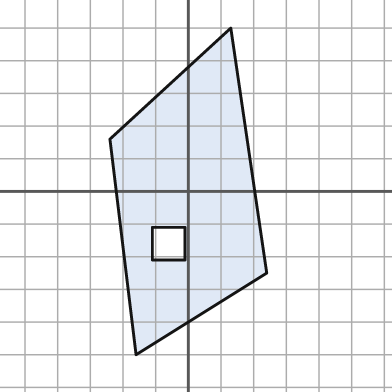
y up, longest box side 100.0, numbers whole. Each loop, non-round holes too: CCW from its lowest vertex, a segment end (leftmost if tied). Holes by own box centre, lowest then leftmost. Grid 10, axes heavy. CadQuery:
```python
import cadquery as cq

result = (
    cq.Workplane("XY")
    .moveTo(-16.0, -50.0)
    .lineTo(24.0, -25.0)
    .lineTo(13.0, 50.0)
    .lineTo(-24.0, 16.0)
    .close()
    .moveTo(-11.0, -21.0)
    .lineTo(-1.0, -21.0)
    .lineTo(-1.0, -11.0)
    .lineTo(-11.0, -11.0)
    .close()
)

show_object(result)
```